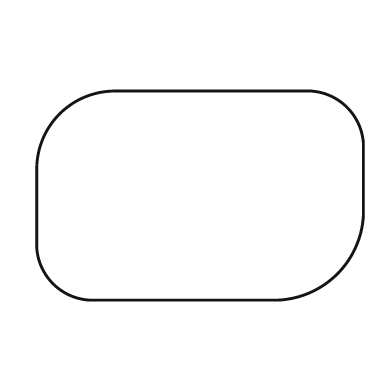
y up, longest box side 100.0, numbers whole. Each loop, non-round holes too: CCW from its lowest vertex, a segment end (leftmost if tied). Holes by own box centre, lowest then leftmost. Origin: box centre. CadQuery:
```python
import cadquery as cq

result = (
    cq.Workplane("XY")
    .moveTo(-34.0, -32.0)
    .lineTo(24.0, -32.0)
    .threePointArc((42.0, -24.0), (50.0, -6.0))
    .lineTo(50.0, 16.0)
    .threePointArc((45.0, 27.0), (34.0, 32.0))
    .lineTo(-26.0, 32.0)
    .threePointArc((-43.0, 25.0), (-50.0, 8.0))
    .lineTo(-50.0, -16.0)
    .threePointArc((-45.0, -27.0), (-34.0, -32.0))
    .close()
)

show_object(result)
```